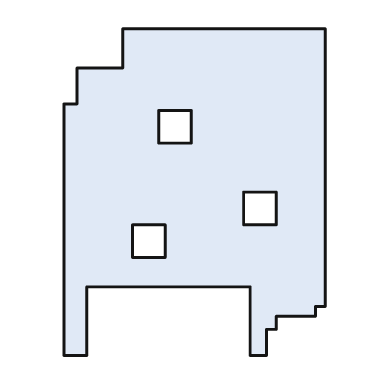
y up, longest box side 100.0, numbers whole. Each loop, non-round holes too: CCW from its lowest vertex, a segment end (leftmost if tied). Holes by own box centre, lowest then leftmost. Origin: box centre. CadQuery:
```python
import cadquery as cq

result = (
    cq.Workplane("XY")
    .moveTo(-40.0, -50.0)
    .lineTo(-33.0, -50.0)
    .lineTo(-33.0, -29.0)
    .lineTo(17.0, -29.0)
    .lineTo(17.0, -50.0)
    .lineTo(22.0, -50.0)
    .lineTo(22.0, -42.0)
    .lineTo(25.0, -42.0)
    .lineTo(25.0, -38.0)
    .lineTo(37.0, -38.0)
    .lineTo(37.0, -35.0)
    .lineTo(40.0, -35.0)
    .lineTo(40.0, 50.0)
    .lineTo(-22.0, 50.0)
    .lineTo(-22.0, 38.0)
    .lineTo(-36.0, 38.0)
    .lineTo(-36.0, 27.0)
    .lineTo(-40.0, 27.0)
    .close()
    .moveTo(-19.0, -20.0)
    .lineTo(-9.0, -20.0)
    .lineTo(-9.0, -10.0)
    .lineTo(-19.0, -10.0)
    .close()
    .moveTo(15.0, -10.0)
    .lineTo(25.0, -10.0)
    .lineTo(25.0, 0.0)
    .lineTo(15.0, 0.0)
    .close()
    .moveTo(-11.0, 15.0)
    .lineTo(-1.0, 15.0)
    .lineTo(-1.0, 25.0)
    .lineTo(-11.0, 25.0)
    .close()
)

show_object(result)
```